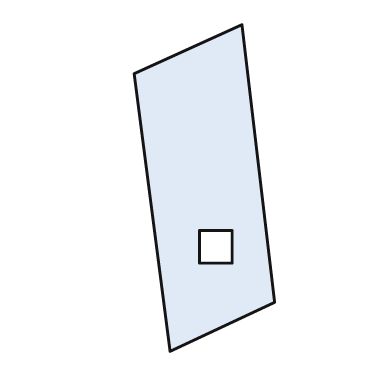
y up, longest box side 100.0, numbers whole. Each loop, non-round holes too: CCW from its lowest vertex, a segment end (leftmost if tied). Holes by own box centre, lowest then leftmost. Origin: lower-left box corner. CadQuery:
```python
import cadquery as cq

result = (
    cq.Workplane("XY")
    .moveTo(11.0, 0.0)
    .lineTo(43.0, 15.0)
    .lineTo(33.0, 100.0)
    .lineTo(0.0, 85.0)
    .close()
    .moveTo(20.0, 27.0)
    .lineTo(30.0, 27.0)
    .lineTo(30.0, 37.0)
    .lineTo(20.0, 37.0)
    .close()
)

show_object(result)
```